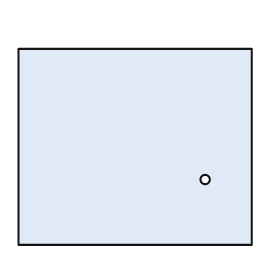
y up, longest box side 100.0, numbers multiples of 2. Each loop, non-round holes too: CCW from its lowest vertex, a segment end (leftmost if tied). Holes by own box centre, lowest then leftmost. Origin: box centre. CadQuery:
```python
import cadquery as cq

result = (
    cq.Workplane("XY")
    .moveTo(-50.0, -42.0)
    .lineTo(50.0, -42.0)
    .lineTo(50.0, 42.0)
    .lineTo(-50.0, 42.0)
    .close()
    .moveTo(30.0, -14.0)
    .circle(2.0)
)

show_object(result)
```